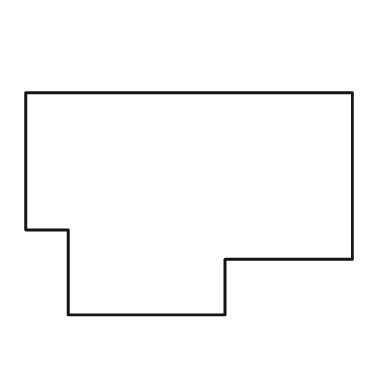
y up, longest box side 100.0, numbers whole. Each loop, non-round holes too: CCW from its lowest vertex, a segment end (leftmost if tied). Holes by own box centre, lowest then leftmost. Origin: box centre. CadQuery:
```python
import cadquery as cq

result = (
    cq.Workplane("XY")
    .moveTo(-37.0, -34.0)
    .lineTo(11.0, -34.0)
    .lineTo(11.0, -17.0)
    .lineTo(50.0, -17.0)
    .lineTo(50.0, 34.0)
    .lineTo(-50.0, 34.0)
    .lineTo(-50.0, -8.0)
    .lineTo(-37.0, -8.0)
    .close()
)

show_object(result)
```